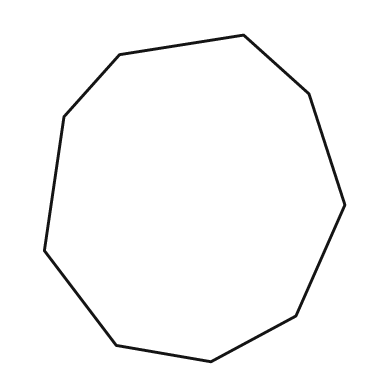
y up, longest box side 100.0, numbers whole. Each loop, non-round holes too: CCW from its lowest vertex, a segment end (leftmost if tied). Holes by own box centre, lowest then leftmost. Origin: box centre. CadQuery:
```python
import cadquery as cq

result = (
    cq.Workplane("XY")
    .moveTo(5.0, -50.0)
    .lineTo(31.0, -36.0)
    .lineTo(46.0, -2.0)
    .lineTo(35.0, 32.0)
    .lineTo(15.0, 50.0)
    .lineTo(-23.0, 44.0)
    .lineTo(-40.0, 25.0)
    .lineTo(-46.0, -16.0)
    .lineTo(-24.0, -45.0)
    .close()
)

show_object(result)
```